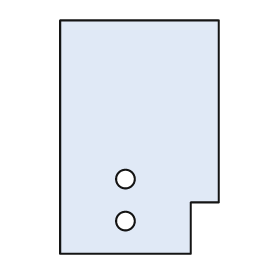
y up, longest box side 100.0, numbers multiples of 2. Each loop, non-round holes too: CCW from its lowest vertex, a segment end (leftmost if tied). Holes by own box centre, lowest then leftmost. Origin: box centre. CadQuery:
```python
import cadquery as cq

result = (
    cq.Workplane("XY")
    .moveTo(-34.0, -50.0)
    .lineTo(22.0, -50.0)
    .lineTo(22.0, -28.0)
    .lineTo(34.0, -28.0)
    .lineTo(34.0, 50.0)
    .lineTo(-34.0, 50.0)
    .close()
    .moveTo(-6.0, -36.0)
    .circle(4.0)
    .moveTo(-6.0, -18.0)
    .circle(4.0)
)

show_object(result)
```